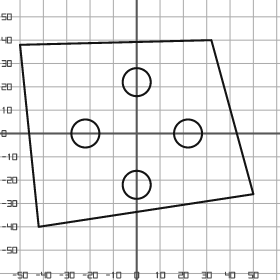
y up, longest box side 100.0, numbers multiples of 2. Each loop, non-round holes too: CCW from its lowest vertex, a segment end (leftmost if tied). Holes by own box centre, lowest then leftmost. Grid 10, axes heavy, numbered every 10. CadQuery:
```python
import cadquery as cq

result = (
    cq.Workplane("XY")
    .moveTo(-42.0, -40.0)
    .lineTo(50.0, -26.0)
    .lineTo(32.0, 40.0)
    .lineTo(-50.0, 38.0)
    .close()
    .moveTo(0.0, -22.0)
    .circle(6.0)
    .moveTo(-22.0, 0.0)
    .circle(6.0)
    .moveTo(22.0, 0.0)
    .circle(6.0)
    .moveTo(0.0, 22.0)
    .circle(6.0)
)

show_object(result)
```